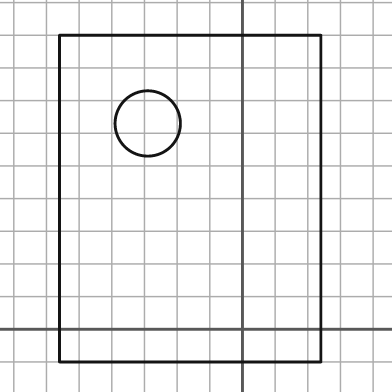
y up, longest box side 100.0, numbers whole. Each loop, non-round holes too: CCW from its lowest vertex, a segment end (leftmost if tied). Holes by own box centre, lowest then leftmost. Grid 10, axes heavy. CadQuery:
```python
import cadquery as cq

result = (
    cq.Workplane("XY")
    .moveTo(-56.0, -10.0)
    .lineTo(24.0, -10.0)
    .lineTo(24.0, 90.0)
    .lineTo(-56.0, 90.0)
    .close()
    .moveTo(-29.0, 63.0)
    .circle(10.0)
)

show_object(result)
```